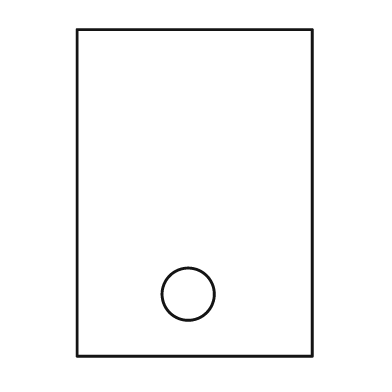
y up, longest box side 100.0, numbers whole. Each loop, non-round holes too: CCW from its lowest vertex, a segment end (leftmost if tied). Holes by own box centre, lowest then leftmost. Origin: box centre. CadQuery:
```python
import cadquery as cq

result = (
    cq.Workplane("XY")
    .moveTo(-36.0, -50.0)
    .lineTo(36.0, -50.0)
    .lineTo(36.0, 50.0)
    .lineTo(-36.0, 50.0)
    .close()
    .moveTo(-2.0, -31.0)
    .circle(8.0)
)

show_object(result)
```